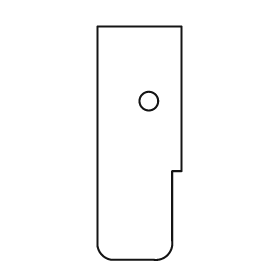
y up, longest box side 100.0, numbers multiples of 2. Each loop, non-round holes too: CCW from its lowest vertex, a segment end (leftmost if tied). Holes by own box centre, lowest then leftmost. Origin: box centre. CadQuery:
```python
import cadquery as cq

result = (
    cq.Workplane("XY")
    .moveTo(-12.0, -50.0)
    .lineTo(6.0, -50.0)
    .threePointArc((12.0, -48.0), (14.0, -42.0))
    .lineTo(14.0, -12.0)
    .lineTo(18.0, -12.0)
    .lineTo(18.0, 50.0)
    .lineTo(-18.0, 50.0)
    .lineTo(-18.0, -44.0)
    .threePointArc((-16.0, -48.0), (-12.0, -50.0))
    .close()
    .moveTo(4.0, 18.0)
    .circle(4.0)
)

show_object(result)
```